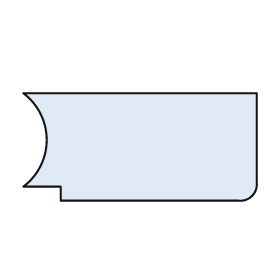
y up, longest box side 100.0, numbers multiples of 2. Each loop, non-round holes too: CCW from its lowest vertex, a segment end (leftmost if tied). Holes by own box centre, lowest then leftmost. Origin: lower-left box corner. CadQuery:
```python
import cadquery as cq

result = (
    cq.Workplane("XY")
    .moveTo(16.0, 0.0)
    .lineTo(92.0, 0.0)
    .threePointArc((98.0, 2.0), (100.0, 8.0))
    .lineTo(100.0, 46.0)
    .lineTo(0.0, 46.0)
    .threePointArc((10.0, 26.0), (0.0, 6.0))
    .lineTo(16.0, 6.0)
    .close()
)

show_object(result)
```